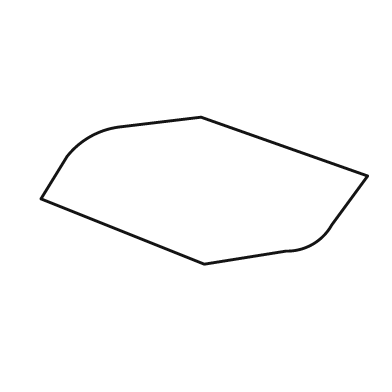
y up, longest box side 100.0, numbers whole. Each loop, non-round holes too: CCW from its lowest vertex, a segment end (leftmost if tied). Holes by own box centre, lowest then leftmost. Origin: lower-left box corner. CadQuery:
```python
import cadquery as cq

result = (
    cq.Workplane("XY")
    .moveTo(50.0, 0.0)
    .lineTo(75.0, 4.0)
    .threePointArc((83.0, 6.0), (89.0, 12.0))
    .lineTo(100.0, 27.0)
    .lineTo(49.0, 45.0)
    .lineTo(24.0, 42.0)
    .threePointArc((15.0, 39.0), (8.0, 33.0))
    .lineTo(0.0, 20.0)
    .close()
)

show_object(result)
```